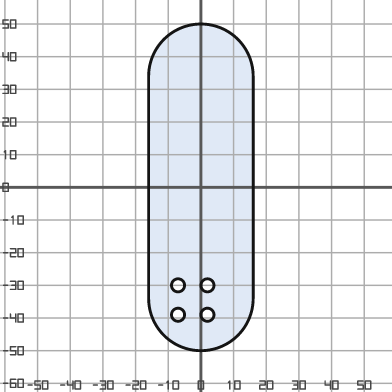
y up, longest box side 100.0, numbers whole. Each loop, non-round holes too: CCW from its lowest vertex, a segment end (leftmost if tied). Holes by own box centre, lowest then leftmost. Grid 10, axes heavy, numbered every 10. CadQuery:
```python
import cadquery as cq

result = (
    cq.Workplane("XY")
    .moveTo(-16.0, -34.0)
    .threePointArc((0.0, -50.0), (16.0, -34.0))
    .lineTo(16.0, 34.0)
    .threePointArc((0.0, 50.0), (-16.0, 34.0))
    .close()
    .moveTo(-7.0, -39.0)
    .circle(2.0)
    .moveTo(2.0, -39.0)
    .circle(2.0)
    .moveTo(-7.0, -30.0)
    .circle(2.0)
    .moveTo(2.0, -30.0)
    .circle(2.0)
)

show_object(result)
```